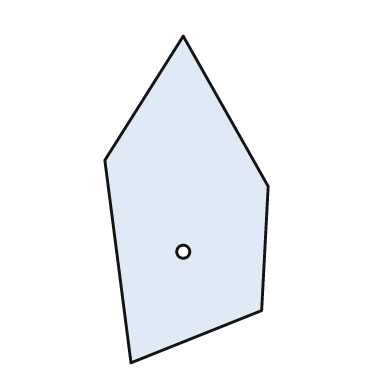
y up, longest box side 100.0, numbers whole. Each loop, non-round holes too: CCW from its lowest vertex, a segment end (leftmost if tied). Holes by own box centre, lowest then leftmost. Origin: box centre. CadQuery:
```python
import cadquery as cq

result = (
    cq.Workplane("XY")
    .moveTo(-17.0, -50.0)
    .lineTo(23.0, -34.0)
    .lineTo(25.0, 4.0)
    .lineTo(-1.0, 50.0)
    .lineTo(-25.0, 12.0)
    .close()
    .moveTo(-1.0, -16.0)
    .circle(2.0)
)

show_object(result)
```